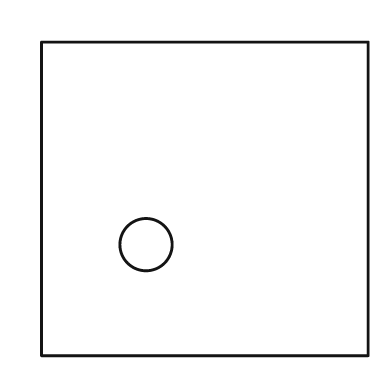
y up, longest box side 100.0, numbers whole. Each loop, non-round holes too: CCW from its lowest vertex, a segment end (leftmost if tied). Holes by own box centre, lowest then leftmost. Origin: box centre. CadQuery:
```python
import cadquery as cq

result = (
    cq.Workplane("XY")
    .moveTo(-50.0, -48.0)
    .lineTo(50.0, -48.0)
    .lineTo(50.0, 48.0)
    .lineTo(-50.0, 48.0)
    .close()
    .moveTo(-18.0, -14.0)
    .circle(8.0)
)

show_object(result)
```